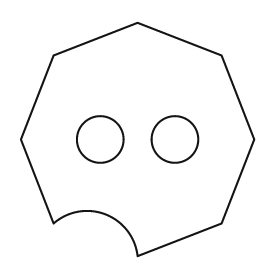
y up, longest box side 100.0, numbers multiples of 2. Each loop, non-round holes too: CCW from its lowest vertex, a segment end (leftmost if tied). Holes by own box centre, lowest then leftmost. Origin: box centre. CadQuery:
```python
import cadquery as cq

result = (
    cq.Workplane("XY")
    .moveTo(0.0, -50.0)
    .lineTo(36.0, -36.0)
    .lineTo(50.0, 0.0)
    .lineTo(36.0, 36.0)
    .lineTo(0.0, 50.0)
    .lineTo(-36.0, 36.0)
    .lineTo(-50.0, 0.0)
    .lineTo(-36.0, -36.0)
    .threePointArc((-14.0, -32.0), (0.0, -50.0))
    .close()
    .moveTo(-16.0, 0.0)
    .circle(10.0)
    .moveTo(16.0, 0.0)
    .circle(10.0)
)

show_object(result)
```